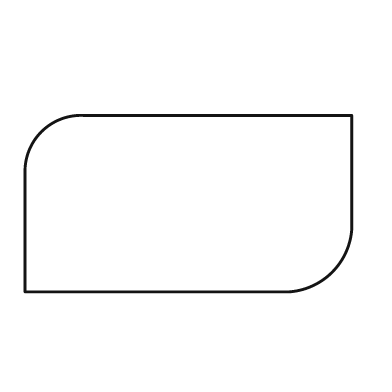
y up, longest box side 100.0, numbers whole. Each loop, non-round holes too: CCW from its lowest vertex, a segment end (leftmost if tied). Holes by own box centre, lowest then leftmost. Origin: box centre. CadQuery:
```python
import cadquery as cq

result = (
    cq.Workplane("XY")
    .moveTo(-50.0, -27.0)
    .lineTo(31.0, -27.0)
    .threePointArc((44.0, -21.0), (50.0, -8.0))
    .lineTo(50.0, 27.0)
    .lineTo(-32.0, 27.0)
    .threePointArc((-45.0, 22.0), (-50.0, 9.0))
    .close()
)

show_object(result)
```